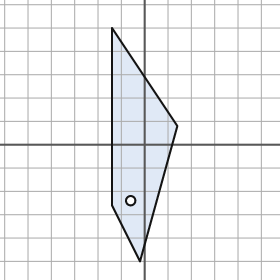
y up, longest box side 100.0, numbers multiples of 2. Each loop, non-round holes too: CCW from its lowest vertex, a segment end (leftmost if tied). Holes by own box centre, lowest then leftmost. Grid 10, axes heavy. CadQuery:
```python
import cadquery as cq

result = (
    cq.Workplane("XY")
    .moveTo(-2.0, -50.0)
    .lineTo(14.0, 8.0)
    .lineTo(-14.0, 50.0)
    .lineTo(-14.0, -26.0)
    .close()
    .moveTo(-6.0, -24.0)
    .circle(2.0)
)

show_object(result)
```